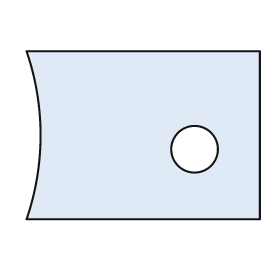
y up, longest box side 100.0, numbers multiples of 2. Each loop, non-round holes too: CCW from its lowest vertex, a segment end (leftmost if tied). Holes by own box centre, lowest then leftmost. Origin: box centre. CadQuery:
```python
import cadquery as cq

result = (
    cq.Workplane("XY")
    .moveTo(-50.0, -36.0)
    .lineTo(50.0, -36.0)
    .lineTo(50.0, 36.0)
    .lineTo(-50.0, 36.0)
    .threePointArc((-44.0, 0.0), (-50.0, -36.0))
    .close()
    .moveTo(22.0, -6.0)
    .circle(10.0)
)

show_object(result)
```